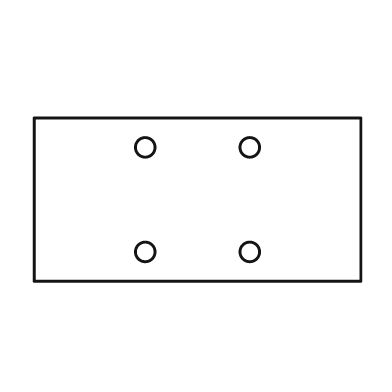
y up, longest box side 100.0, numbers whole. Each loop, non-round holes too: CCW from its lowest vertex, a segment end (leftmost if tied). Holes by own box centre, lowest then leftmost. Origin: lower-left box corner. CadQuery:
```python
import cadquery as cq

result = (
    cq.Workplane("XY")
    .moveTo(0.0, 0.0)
    .lineTo(100.0, 0.0)
    .lineTo(100.0, 50.0)
    .lineTo(0.0, 50.0)
    .close()
    .moveTo(34.0, 9.0)
    .circle(3.0)
    .moveTo(66.0, 9.0)
    .circle(3.0)
    .moveTo(34.0, 41.0)
    .circle(3.0)
    .moveTo(66.0, 41.0)
    .circle(3.0)
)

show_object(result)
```